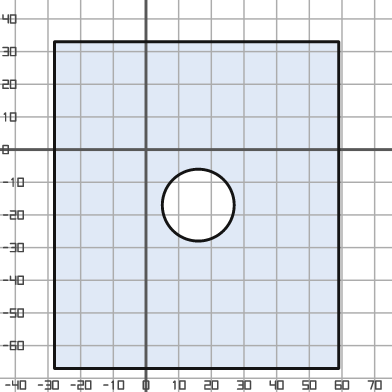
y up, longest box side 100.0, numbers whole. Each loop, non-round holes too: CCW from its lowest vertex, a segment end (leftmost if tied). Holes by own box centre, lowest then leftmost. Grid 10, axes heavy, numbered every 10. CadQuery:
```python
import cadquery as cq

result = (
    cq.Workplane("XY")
    .moveTo(-28.0, -67.0)
    .lineTo(59.0, -67.0)
    .lineTo(59.0, 33.0)
    .lineTo(-28.0, 33.0)
    .close()
    .moveTo(16.0, -17.0)
    .circle(11.0)
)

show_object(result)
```